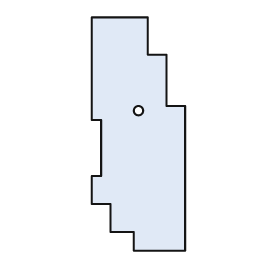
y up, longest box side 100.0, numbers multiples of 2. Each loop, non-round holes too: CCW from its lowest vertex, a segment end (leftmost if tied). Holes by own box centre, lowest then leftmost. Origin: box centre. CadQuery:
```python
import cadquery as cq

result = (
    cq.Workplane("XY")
    .moveTo(-2.0, -50.0)
    .lineTo(20.0, -50.0)
    .lineTo(20.0, 12.0)
    .lineTo(12.0, 12.0)
    .lineTo(12.0, 34.0)
    .lineTo(4.0, 34.0)
    .lineTo(4.0, 50.0)
    .lineTo(-20.0, 50.0)
    .lineTo(-20.0, 6.0)
    .lineTo(-16.0, 6.0)
    .lineTo(-16.0, -18.0)
    .lineTo(-20.0, -18.0)
    .lineTo(-20.0, -30.0)
    .lineTo(-12.0, -30.0)
    .lineTo(-12.0, -42.0)
    .lineTo(-2.0, -42.0)
    .close()
    .moveTo(0.0, 10.0)
    .circle(2.0)
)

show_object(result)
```